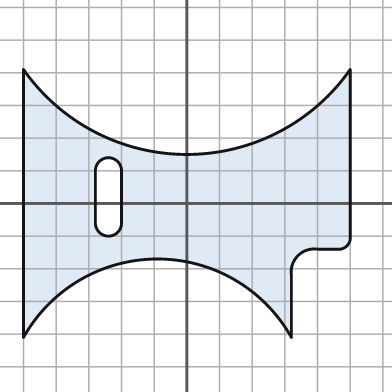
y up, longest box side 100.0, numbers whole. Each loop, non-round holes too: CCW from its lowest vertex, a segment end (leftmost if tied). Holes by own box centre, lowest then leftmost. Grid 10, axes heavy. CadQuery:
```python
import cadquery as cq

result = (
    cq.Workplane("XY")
    .moveTo(-50.0, -41.0)
    .threePointArc((-9.0, -17.0), (32.0, -41.0))
    .lineTo(32.0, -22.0)
    .threePointArc((34.0, -16.0), (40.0, -14.0))
    .lineTo(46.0, -14.0)
    .threePointArc((49.0, -13.0), (50.0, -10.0))
    .lineTo(50.0, 41.0)
    .threePointArc((0.0, 15.0), (-50.0, 41.0))
    .close()
    .moveTo(-28.0, -6.0)
    .threePointArc((-24.0, -10.0), (-20.0, -6.0))
    .lineTo(-20.0, 10.0)
    .threePointArc((-24.0, 14.0), (-28.0, 10.0))
    .close()
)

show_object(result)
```